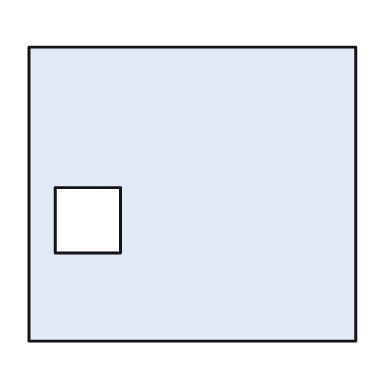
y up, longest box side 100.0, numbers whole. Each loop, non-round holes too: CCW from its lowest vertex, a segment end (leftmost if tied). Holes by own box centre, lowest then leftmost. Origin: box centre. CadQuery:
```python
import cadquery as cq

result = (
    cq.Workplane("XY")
    .moveTo(-50.0, -45.0)
    .lineTo(50.0, -45.0)
    .lineTo(50.0, 45.0)
    .lineTo(-50.0, 45.0)
    .close()
    .moveTo(-42.0, -18.0)
    .lineTo(-22.0, -18.0)
    .lineTo(-22.0, 2.0)
    .lineTo(-42.0, 2.0)
    .close()
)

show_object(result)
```